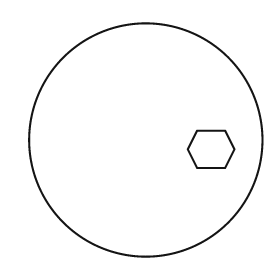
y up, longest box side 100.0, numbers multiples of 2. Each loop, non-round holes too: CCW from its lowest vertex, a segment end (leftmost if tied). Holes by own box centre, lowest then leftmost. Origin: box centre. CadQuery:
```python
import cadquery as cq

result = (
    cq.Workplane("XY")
    .moveTo(0.0, 0.0)
    .circle(50.0)
    .moveTo(22.0, -12.0)
    .lineTo(34.0, -12.0)
    .lineTo(38.0, -4.0)
    .lineTo(34.0, 4.0)
    .lineTo(22.0, 4.0)
    .lineTo(18.0, -4.0)
    .close()
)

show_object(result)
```